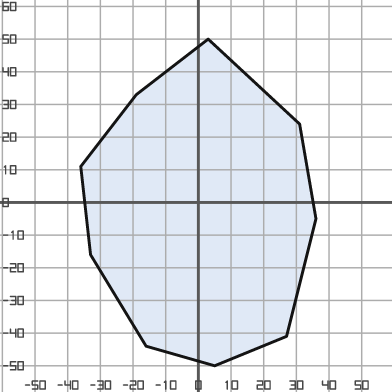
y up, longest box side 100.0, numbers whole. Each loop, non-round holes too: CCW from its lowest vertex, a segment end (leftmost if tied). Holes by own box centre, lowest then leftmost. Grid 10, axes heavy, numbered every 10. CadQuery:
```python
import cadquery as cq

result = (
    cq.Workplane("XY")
    .moveTo(5.0, -50.0)
    .lineTo(27.0, -41.0)
    .lineTo(36.0, -5.0)
    .lineTo(31.0, 24.0)
    .lineTo(3.0, 50.0)
    .lineTo(-19.0, 33.0)
    .lineTo(-36.0, 11.0)
    .lineTo(-33.0, -16.0)
    .lineTo(-16.0, -44.0)
    .close()
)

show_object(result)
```